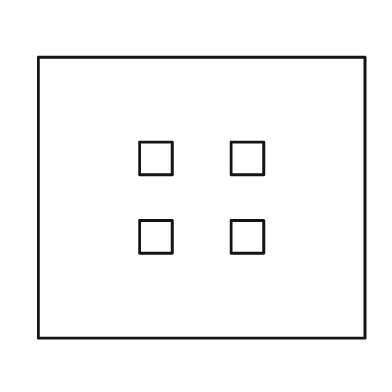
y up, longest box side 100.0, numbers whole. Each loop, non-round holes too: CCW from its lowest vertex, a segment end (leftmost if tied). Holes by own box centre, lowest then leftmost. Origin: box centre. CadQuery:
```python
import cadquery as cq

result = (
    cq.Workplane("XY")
    .moveTo(-50.0, -43.0)
    .lineTo(50.0, -43.0)
    .lineTo(50.0, 43.0)
    .lineTo(-50.0, 43.0)
    .close()
    .moveTo(-19.0, -17.0)
    .lineTo(-9.0, -17.0)
    .lineTo(-9.0, -7.0)
    .lineTo(-19.0, -7.0)
    .close()
    .moveTo(9.0, -17.0)
    .lineTo(19.0, -17.0)
    .lineTo(19.0, -7.0)
    .lineTo(9.0, -7.0)
    .close()
    .moveTo(-19.0, 7.0)
    .lineTo(-9.0, 7.0)
    .lineTo(-9.0, 17.0)
    .lineTo(-19.0, 17.0)
    .close()
    .moveTo(9.0, 7.0)
    .lineTo(19.0, 7.0)
    .lineTo(19.0, 17.0)
    .lineTo(9.0, 17.0)
    .close()
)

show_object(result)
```